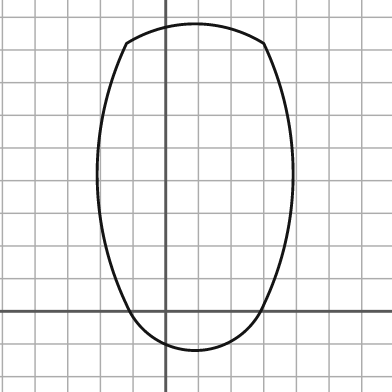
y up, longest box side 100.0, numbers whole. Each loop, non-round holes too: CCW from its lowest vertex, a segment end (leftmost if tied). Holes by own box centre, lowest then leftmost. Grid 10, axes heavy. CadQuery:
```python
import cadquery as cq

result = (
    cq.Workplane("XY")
    .moveTo(-12.0, 2.0)
    .threePointArc((9.0, -12.0), (30.0, 2.0))
    .threePointArc((39.0, 42.0), (30.0, 82.0))
    .threePointArc((9.0, 88.0), (-12.0, 82.0))
    .threePointArc((-21.0, 42.0), (-12.0, 2.0))
    .close()
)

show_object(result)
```